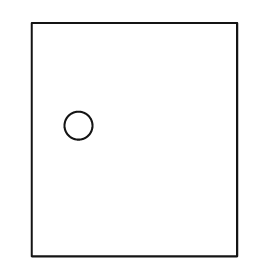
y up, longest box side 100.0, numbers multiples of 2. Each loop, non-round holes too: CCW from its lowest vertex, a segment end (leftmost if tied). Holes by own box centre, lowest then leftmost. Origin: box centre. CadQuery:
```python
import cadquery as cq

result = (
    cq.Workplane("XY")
    .moveTo(-44.0, -50.0)
    .lineTo(44.0, -50.0)
    .lineTo(44.0, 50.0)
    .lineTo(-44.0, 50.0)
    .close()
    .moveTo(-24.0, 6.0)
    .circle(6.0)
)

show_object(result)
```